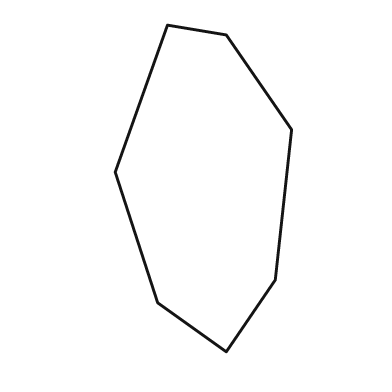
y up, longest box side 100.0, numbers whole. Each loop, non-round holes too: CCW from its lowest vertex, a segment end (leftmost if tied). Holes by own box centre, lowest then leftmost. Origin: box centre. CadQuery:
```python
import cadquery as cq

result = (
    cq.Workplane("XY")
    .moveTo(7.0, -50.0)
    .lineTo(22.0, -28.0)
    .lineTo(27.0, 18.0)
    .lineTo(7.0, 47.0)
    .lineTo(-11.0, 50.0)
    .lineTo(-27.0, 5.0)
    .lineTo(-14.0, -35.0)
    .close()
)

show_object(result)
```